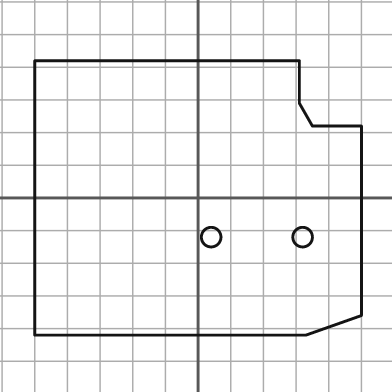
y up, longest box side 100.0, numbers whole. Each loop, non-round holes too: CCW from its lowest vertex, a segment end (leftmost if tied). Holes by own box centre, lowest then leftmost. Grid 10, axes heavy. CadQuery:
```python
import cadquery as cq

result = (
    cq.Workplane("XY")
    .moveTo(-50.0, -42.0)
    .lineTo(33.0, -42.0)
    .lineTo(50.0, -36.0)
    .lineTo(50.0, 22.0)
    .lineTo(35.0, 22.0)
    .lineTo(31.0, 29.0)
    .lineTo(31.0, 42.0)
    .lineTo(-50.0, 42.0)
    .close()
    .moveTo(4.0, -12.0)
    .circle(3.0)
    .moveTo(32.0, -12.0)
    .circle(3.0)
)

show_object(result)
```